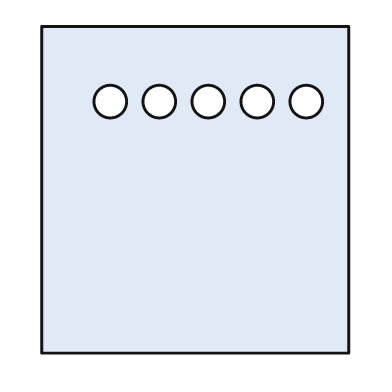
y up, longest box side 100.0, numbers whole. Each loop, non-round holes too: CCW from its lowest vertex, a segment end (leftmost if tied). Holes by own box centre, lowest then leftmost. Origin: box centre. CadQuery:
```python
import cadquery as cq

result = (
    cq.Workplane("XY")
    .moveTo(-47.0, -50.0)
    .lineTo(47.0, -50.0)
    .lineTo(47.0, 50.0)
    .lineTo(-47.0, 50.0)
    .close()
    .moveTo(-26.0, 27.0)
    .circle(5.0)
    .moveTo(-11.0, 27.0)
    .circle(5.0)
    .moveTo(4.0, 27.0)
    .circle(5.0)
    .moveTo(19.0, 27.0)
    .circle(5.0)
    .moveTo(34.0, 27.0)
    .circle(5.0)
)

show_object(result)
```